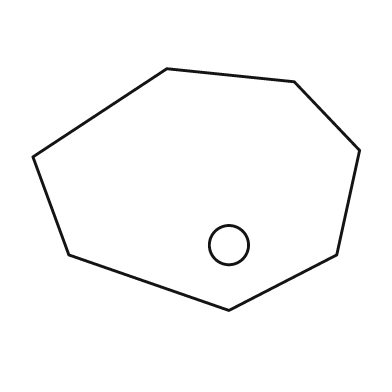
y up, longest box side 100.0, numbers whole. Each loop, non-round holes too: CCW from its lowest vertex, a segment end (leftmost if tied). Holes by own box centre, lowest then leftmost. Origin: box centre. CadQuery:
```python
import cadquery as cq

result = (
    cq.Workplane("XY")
    .moveTo(10.0, -37.0)
    .lineTo(43.0, -20.0)
    .lineTo(50.0, 12.0)
    .lineTo(30.0, 33.0)
    .lineTo(-9.0, 37.0)
    .lineTo(-50.0, 10.0)
    .lineTo(-39.0, -20.0)
    .close()
    .moveTo(10.0, -17.0)
    .circle(6.0)
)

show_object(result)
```